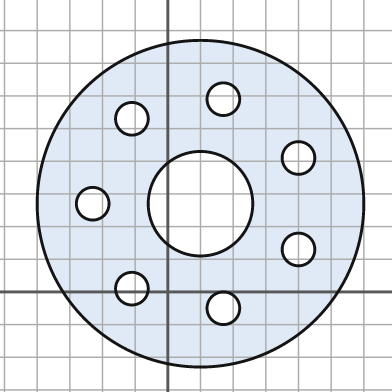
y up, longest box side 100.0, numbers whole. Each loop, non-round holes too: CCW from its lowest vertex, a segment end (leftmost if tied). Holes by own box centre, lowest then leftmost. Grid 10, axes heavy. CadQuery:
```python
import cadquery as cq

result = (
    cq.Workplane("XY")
    .moveTo(10.0, 27.0)
    .circle(50.0)
    .moveTo(17.0, -5.0)
    .circle(5.0)
    .moveTo(-11.0, 1.0)
    .circle(5.0)
    .moveTo(40.0, 13.0)
    .circle(5.0)
    .moveTo(-23.0, 27.0)
    .circle(5.0)
    .moveTo(10.0, 27.0)
    .circle(16.0)
    .moveTo(40.0, 41.0)
    .circle(5.0)
    .moveTo(-11.0, 53.0)
    .circle(5.0)
    .moveTo(17.0, 59.0)
    .circle(5.0)
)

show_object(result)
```